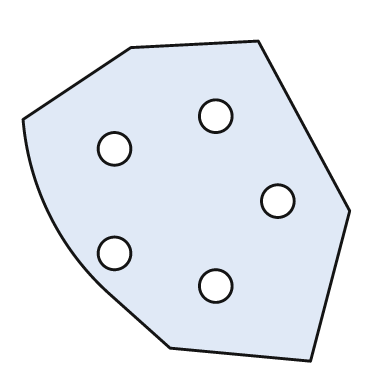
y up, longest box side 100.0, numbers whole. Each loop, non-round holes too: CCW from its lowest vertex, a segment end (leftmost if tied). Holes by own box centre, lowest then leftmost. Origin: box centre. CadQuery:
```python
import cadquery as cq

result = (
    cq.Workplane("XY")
    .moveTo(38.0, -49.0)
    .lineTo(50.0, -3.0)
    .lineTo(22.0, 49.0)
    .lineTo(-17.0, 47.0)
    .lineTo(-50.0, 25.0)
    .threePointArc((-42.0, -4.0), (-24.0, -28.0))
    .lineTo(-5.0, -45.0)
    .close()
    .moveTo(9.0, -26.0)
    .circle(5.0)
    .moveTo(-22.0, -16.0)
    .circle(5.0)
    .moveTo(28.0, 0.0)
    .circle(5.0)
    .moveTo(-22.0, 16.0)
    .circle(5.0)
    .moveTo(9.0, 26.0)
    .circle(5.0)
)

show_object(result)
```